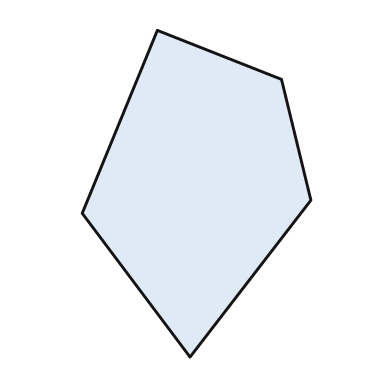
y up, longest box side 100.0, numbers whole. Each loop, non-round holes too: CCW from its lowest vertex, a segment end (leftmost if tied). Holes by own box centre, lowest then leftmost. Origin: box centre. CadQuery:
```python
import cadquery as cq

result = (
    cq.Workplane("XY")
    .moveTo(-2.0, -50.0)
    .lineTo(35.0, -2.0)
    .lineTo(26.0, 35.0)
    .lineTo(-12.0, 50.0)
    .lineTo(-35.0, -6.0)
    .close()
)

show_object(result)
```